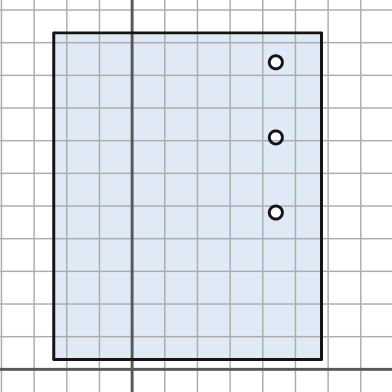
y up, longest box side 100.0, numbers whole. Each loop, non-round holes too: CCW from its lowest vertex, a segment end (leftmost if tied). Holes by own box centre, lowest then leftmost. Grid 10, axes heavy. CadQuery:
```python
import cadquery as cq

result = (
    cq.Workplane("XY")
    .moveTo(-24.0, 3.0)
    .lineTo(58.0, 3.0)
    .lineTo(58.0, 103.0)
    .lineTo(-24.0, 103.0)
    .close()
    .moveTo(44.0, 48.0)
    .circle(2.0)
    .moveTo(44.0, 71.0)
    .circle(2.0)
    .moveTo(44.0, 94.0)
    .circle(2.0)
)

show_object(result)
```